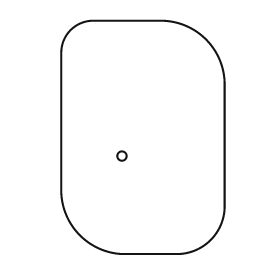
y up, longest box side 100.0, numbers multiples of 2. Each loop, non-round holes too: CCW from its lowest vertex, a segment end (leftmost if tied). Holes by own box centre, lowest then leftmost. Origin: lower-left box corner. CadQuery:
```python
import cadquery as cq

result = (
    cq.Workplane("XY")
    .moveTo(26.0, 0.0)
    .lineTo(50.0, 0.0)
    .threePointArc((64.0, 6.0), (70.0, 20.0))
    .lineTo(70.0, 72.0)
    .threePointArc((62.0, 92.0), (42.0, 100.0))
    .lineTo(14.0, 100.0)
    .threePointArc((4.0, 96.0), (0.0, 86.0))
    .lineTo(0.0, 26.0)
    .threePointArc((8.0, 8.0), (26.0, 0.0))
    .close()
    .moveTo(26.0, 42.0)
    .circle(2.0)
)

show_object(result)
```